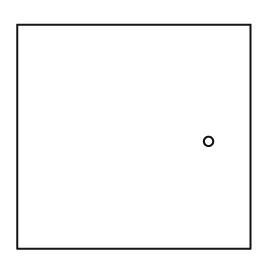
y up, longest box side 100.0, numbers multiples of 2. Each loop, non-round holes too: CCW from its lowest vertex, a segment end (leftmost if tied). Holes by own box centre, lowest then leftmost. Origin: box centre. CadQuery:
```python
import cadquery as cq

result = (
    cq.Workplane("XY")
    .moveTo(-50.0, -48.0)
    .lineTo(50.0, -48.0)
    .lineTo(50.0, 48.0)
    .lineTo(-50.0, 48.0)
    .close()
    .moveTo(32.0, -2.0)
    .circle(2.0)
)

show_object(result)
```